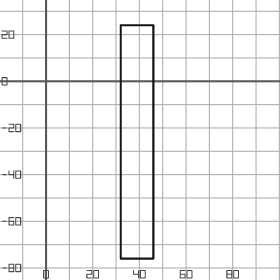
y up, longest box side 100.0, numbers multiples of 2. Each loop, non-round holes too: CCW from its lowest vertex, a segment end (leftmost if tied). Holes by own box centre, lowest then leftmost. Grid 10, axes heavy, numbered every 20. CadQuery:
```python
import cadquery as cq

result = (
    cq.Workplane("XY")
    .moveTo(32.0, -76.0)
    .lineTo(46.0, -76.0)
    .lineTo(46.0, 24.0)
    .lineTo(32.0, 24.0)
    .close()
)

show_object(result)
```